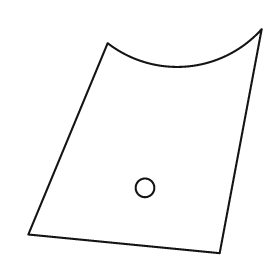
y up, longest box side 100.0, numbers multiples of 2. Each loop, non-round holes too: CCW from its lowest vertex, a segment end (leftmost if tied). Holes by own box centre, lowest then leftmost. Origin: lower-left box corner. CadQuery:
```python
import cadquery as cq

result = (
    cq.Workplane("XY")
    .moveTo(82.0, 0.0)
    .lineTo(100.0, 96.0)
    .threePointArc((68.0, 80.0), (34.0, 90.0))
    .lineTo(0.0, 8.0)
    .close()
    .moveTo(50.0, 28.0)
    .circle(4.0)
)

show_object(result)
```